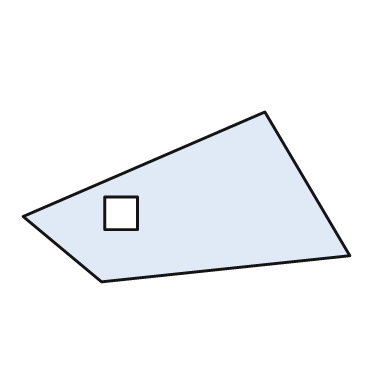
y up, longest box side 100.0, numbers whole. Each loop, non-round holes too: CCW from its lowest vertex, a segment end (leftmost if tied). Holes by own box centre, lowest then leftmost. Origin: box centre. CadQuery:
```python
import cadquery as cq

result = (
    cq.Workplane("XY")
    .moveTo(-26.0, -26.0)
    .lineTo(50.0, -18.0)
    .lineTo(24.0, 26.0)
    .lineTo(-50.0, -6.0)
    .close()
    .moveTo(-25.0, -10.0)
    .lineTo(-15.0, -10.0)
    .lineTo(-15.0, 0.0)
    .lineTo(-25.0, 0.0)
    .close()
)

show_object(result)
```